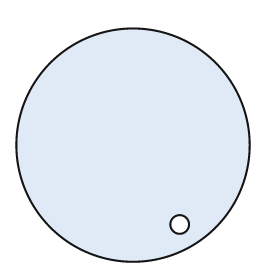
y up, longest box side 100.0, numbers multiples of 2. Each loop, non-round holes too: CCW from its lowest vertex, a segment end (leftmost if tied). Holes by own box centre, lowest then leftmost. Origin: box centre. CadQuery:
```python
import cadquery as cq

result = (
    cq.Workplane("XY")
    .moveTo(0.0, 0.0)
    .circle(50.0)
    .moveTo(20.0, -34.0)
    .circle(4.0)
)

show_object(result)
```